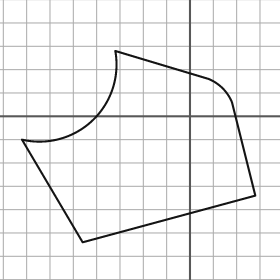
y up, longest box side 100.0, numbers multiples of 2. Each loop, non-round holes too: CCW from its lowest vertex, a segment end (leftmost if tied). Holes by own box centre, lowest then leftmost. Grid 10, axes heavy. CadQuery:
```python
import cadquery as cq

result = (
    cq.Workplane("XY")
    .moveTo(-46.0, -54.0)
    .lineTo(28.0, -34.0)
    .lineTo(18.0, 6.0)
    .threePointArc((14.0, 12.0), (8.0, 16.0))
    .lineTo(-32.0, 28.0)
    .threePointArc((-42.0, -2.0), (-72.0, -10.0))
    .close()
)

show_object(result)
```